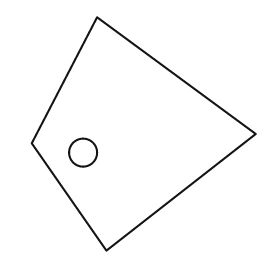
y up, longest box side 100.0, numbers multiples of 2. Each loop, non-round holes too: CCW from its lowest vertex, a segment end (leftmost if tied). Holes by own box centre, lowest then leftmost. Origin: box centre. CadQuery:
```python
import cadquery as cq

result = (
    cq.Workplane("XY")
    .moveTo(-16.0, -50.0)
    .lineTo(48.0, 0.0)
    .lineTo(-20.0, 50.0)
    .lineTo(-48.0, -4.0)
    .close()
    .moveTo(-26.0, -8.0)
    .circle(6.0)
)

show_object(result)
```